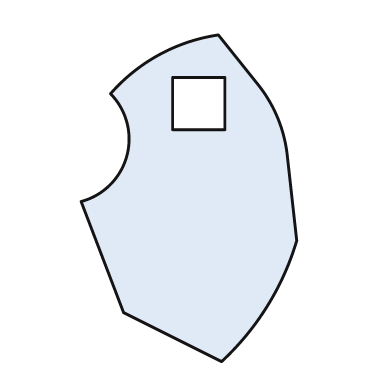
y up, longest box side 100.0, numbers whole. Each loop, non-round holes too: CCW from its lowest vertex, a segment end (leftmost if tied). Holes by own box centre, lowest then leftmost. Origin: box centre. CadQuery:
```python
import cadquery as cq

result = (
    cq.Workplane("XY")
    .moveTo(10.0, -50.0)
    .threePointArc((24.0, -33.0), (33.0, -13.0))
    .lineTo(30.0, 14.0)
    .threePointArc((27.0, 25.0), (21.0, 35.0))
    .lineTo(9.0, 50.0)
    .threePointArc((-9.0, 44.0), (-24.0, 32.0))
    .threePointArc((-19.0, 13.0), (-33.0, -1.0))
    .lineTo(-20.0, -35.0)
    .close()
    .moveTo(-5.0, 21.0)
    .lineTo(11.0, 21.0)
    .lineTo(11.0, 37.0)
    .lineTo(-5.0, 37.0)
    .close()
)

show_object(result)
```